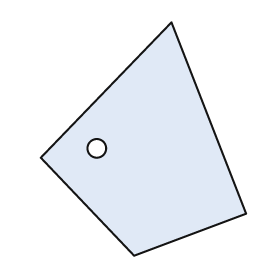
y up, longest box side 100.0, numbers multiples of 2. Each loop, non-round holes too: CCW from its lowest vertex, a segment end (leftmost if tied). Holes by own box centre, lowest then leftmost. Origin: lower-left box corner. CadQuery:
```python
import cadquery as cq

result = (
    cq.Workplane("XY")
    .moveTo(40.0, 0.0)
    .lineTo(88.0, 18.0)
    .lineTo(56.0, 100.0)
    .lineTo(0.0, 42.0)
    .close()
    .moveTo(24.0, 46.0)
    .circle(4.0)
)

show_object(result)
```